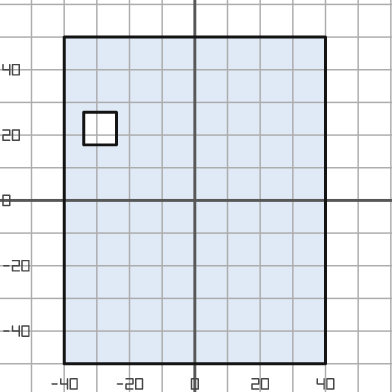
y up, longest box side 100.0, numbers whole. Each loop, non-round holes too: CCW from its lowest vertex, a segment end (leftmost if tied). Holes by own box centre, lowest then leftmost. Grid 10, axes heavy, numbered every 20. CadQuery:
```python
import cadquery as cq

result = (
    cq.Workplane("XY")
    .moveTo(-40.0, -50.0)
    .lineTo(40.0, -50.0)
    .lineTo(40.0, 50.0)
    .lineTo(-40.0, 50.0)
    .close()
    .moveTo(-34.0, 17.0)
    .lineTo(-24.0, 17.0)
    .lineTo(-24.0, 27.0)
    .lineTo(-34.0, 27.0)
    .close()
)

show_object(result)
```